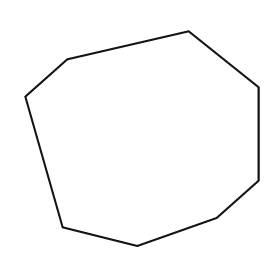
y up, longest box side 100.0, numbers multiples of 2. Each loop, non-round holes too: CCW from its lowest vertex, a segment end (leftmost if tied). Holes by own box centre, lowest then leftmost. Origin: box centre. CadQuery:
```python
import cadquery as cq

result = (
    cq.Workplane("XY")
    .moveTo(-2.0, -46.0)
    .lineTo(32.0, -34.0)
    .lineTo(50.0, -18.0)
    .lineTo(50.0, 22.0)
    .lineTo(20.0, 46.0)
    .lineTo(-32.0, 34.0)
    .lineTo(-50.0, 18.0)
    .lineTo(-34.0, -38.0)
    .close()
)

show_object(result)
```